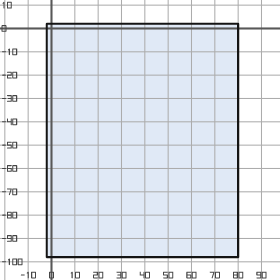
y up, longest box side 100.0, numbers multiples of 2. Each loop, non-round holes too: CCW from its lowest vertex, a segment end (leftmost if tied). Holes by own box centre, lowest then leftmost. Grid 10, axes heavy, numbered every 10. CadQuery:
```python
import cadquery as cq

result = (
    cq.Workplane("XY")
    .moveTo(-2.0, -98.0)
    .lineTo(80.0, -98.0)
    .lineTo(80.0, 2.0)
    .lineTo(-2.0, 2.0)
    .close()
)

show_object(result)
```